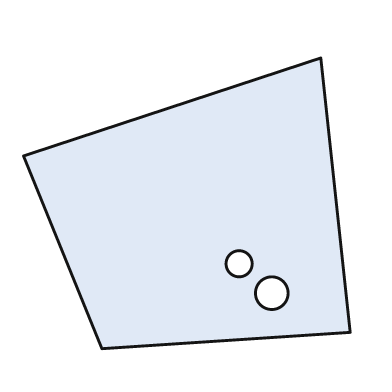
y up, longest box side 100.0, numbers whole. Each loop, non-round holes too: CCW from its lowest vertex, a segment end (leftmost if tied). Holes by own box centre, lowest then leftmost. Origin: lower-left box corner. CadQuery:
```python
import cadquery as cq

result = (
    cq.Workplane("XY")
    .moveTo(24.0, 0.0)
    .lineTo(100.0, 5.0)
    .lineTo(91.0, 89.0)
    .lineTo(0.0, 59.0)
    .close()
    .moveTo(76.0, 17.0)
    .circle(5.0)
    .moveTo(66.0, 26.0)
    .circle(4.0)
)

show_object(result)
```